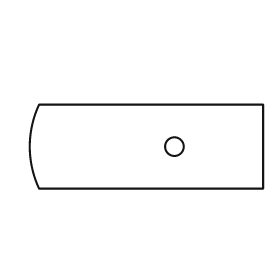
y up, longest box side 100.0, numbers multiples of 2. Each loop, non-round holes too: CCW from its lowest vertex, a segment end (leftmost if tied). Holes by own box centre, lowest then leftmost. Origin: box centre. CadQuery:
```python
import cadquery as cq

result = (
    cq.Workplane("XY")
    .moveTo(-46.0, -18.0)
    .lineTo(50.0, -18.0)
    .lineTo(50.0, 18.0)
    .lineTo(-46.0, 18.0)
    .threePointArc((-50.0, 0.0), (-46.0, -18.0))
    .close()
    .moveTo(12.0, 0.0)
    .circle(4.0)
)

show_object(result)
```